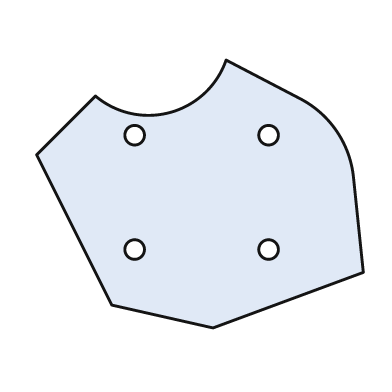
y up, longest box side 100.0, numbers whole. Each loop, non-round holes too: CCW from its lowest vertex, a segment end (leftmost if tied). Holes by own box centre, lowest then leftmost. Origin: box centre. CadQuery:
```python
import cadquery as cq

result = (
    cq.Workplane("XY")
    .moveTo(4.0, -41.0)
    .lineTo(50.0, -24.0)
    .lineTo(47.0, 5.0)
    .threePointArc((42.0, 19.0), (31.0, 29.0))
    .lineTo(8.0, 41.0)
    .threePointArc((-9.0, 25.0), (-32.0, 30.0))
    .lineTo(-50.0, 12.0)
    .lineTo(-27.0, -34.0)
    .close()
    .moveTo(-20.0, -17.0)
    .circle(3.0)
    .moveTo(21.0, -17.0)
    .circle(3.0)
    .moveTo(-20.0, 18.0)
    .circle(3.0)
    .moveTo(21.0, 18.0)
    .circle(3.0)
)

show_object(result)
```